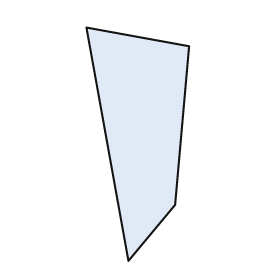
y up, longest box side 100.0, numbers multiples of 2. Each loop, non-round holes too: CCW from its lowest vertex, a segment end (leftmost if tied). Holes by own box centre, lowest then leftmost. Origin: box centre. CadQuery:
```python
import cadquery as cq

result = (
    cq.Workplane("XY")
    .moveTo(-4.0, -50.0)
    .lineTo(16.0, -26.0)
    .lineTo(22.0, 42.0)
    .lineTo(-22.0, 50.0)
    .close()
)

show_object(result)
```